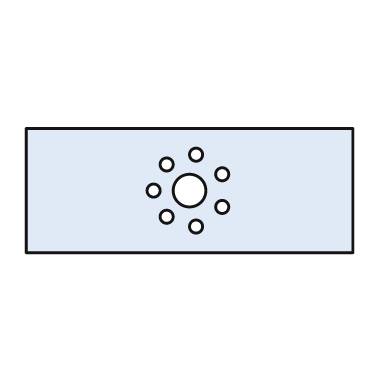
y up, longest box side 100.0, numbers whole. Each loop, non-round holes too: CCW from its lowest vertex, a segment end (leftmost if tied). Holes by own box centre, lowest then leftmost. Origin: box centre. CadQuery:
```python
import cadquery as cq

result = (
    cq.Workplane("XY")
    .moveTo(-50.0, -19.0)
    .lineTo(50.0, -19.0)
    .lineTo(50.0, 19.0)
    .lineTo(-50.0, 19.0)
    .close()
    .moveTo(2.0, -11.0)
    .circle(2.0)
    .moveTo(-7.0, -8.0)
    .circle(2.0)
    .moveTo(10.0, -5.0)
    .circle(2.0)
    .moveTo(-11.0, 0.0)
    .circle(2.0)
    .moveTo(0.0, 0.0)
    .circle(5.0)
    .moveTo(10.0, 5.0)
    .circle(2.0)
    .moveTo(-7.0, 8.0)
    .circle(2.0)
    .moveTo(2.0, 11.0)
    .circle(2.0)
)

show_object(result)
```